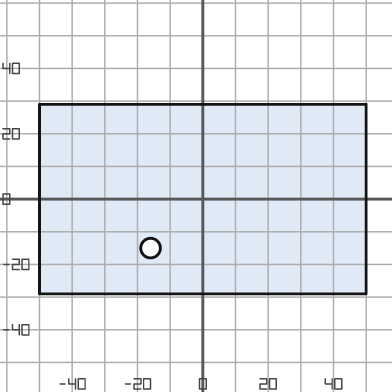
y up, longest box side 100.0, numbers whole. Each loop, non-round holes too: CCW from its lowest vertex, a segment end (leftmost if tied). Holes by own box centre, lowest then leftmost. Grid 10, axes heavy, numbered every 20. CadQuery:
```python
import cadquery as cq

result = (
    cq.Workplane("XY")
    .moveTo(-50.0, -29.0)
    .lineTo(50.0, -29.0)
    .lineTo(50.0, 29.0)
    .lineTo(-50.0, 29.0)
    .close()
    .moveTo(-16.0, -15.0)
    .circle(3.0)
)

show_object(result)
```